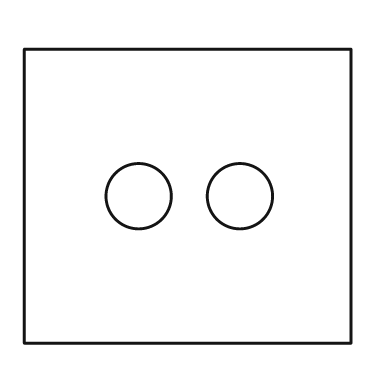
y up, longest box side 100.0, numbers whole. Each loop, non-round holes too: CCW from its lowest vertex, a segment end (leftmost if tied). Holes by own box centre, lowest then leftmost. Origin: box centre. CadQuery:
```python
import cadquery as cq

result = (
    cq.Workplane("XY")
    .moveTo(-50.0, -45.0)
    .lineTo(50.0, -45.0)
    .lineTo(50.0, 45.0)
    .lineTo(-50.0, 45.0)
    .close()
    .moveTo(-15.0, 0.0)
    .circle(10.0)
    .moveTo(16.0, 0.0)
    .circle(10.0)
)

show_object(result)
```